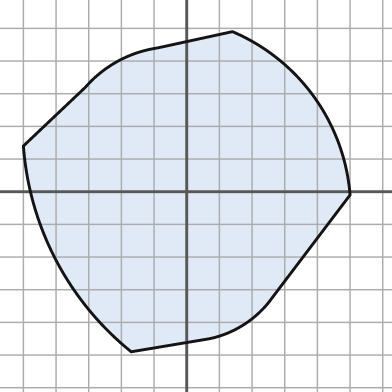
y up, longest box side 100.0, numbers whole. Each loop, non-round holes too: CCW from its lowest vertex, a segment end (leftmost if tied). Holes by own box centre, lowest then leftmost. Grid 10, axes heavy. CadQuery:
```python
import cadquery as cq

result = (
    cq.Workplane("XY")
    .moveTo(-17.0, -49.0)
    .lineTo(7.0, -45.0)
    .threePointArc((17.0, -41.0), (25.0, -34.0))
    .lineTo(50.0, -1.0)
    .threePointArc((39.0, 29.0), (14.0, 49.0))
    .lineTo(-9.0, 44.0)
    .threePointArc((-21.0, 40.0), (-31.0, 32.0))
    .lineTo(-50.0, 14.0)
    .threePointArc((-40.0, -21.0), (-17.0, -49.0))
    .close()
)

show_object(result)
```